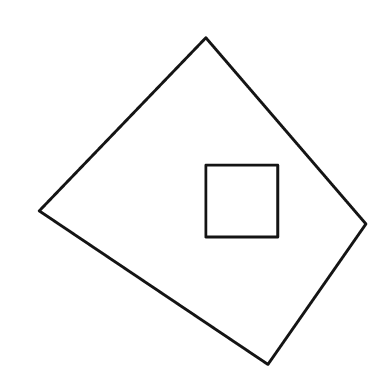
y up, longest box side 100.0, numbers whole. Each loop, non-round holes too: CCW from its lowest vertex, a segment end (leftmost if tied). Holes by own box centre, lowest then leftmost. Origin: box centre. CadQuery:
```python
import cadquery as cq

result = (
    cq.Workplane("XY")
    .moveTo(20.0, -50.0)
    .lineTo(50.0, -7.0)
    .lineTo(1.0, 50.0)
    .lineTo(-50.0, -3.0)
    .close()
    .moveTo(1.0, -11.0)
    .lineTo(23.0, -11.0)
    .lineTo(23.0, 11.0)
    .lineTo(1.0, 11.0)
    .close()
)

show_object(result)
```